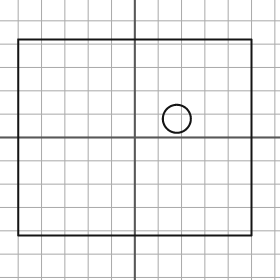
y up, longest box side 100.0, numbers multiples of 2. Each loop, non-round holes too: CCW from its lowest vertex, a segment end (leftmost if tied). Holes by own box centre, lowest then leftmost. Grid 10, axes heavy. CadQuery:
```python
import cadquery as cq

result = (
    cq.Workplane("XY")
    .moveTo(-50.0, -42.0)
    .lineTo(50.0, -42.0)
    .lineTo(50.0, 42.0)
    .lineTo(-50.0, 42.0)
    .close()
    .moveTo(18.0, 8.0)
    .circle(6.0)
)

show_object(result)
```